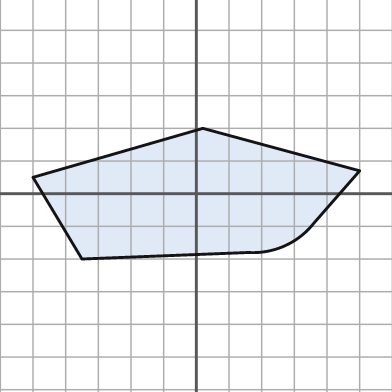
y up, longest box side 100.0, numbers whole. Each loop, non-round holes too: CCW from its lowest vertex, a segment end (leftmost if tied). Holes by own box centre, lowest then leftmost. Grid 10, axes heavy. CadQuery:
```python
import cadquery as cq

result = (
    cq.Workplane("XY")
    .moveTo(-35.0, -20.0)
    .lineTo(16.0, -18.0)
    .threePointArc((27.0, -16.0), (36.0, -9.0))
    .lineTo(50.0, 7.0)
    .lineTo(2.0, 20.0)
    .lineTo(-50.0, 5.0)
    .close()
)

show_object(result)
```